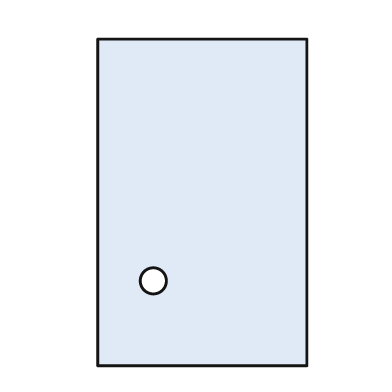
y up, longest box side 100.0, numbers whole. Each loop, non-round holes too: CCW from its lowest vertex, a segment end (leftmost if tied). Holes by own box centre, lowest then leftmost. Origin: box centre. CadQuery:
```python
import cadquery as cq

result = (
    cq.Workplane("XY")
    .moveTo(-32.0, -50.0)
    .lineTo(32.0, -50.0)
    .lineTo(32.0, 50.0)
    .lineTo(-32.0, 50.0)
    .close()
    .moveTo(-15.0, -24.0)
    .circle(4.0)
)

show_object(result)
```